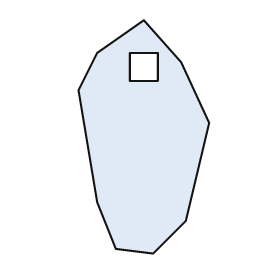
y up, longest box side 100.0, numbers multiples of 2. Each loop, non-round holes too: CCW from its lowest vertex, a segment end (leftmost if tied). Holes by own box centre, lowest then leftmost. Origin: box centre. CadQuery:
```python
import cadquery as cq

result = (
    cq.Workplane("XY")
    .moveTo(4.0, -50.0)
    .lineTo(18.0, -36.0)
    .lineTo(28.0, 6.0)
    .lineTo(16.0, 32.0)
    .lineTo(0.0, 50.0)
    .lineTo(-20.0, 36.0)
    .lineTo(-28.0, 20.0)
    .lineTo(-20.0, -28.0)
    .lineTo(-12.0, -48.0)
    .close()
    .moveTo(-6.0, 24.0)
    .lineTo(6.0, 24.0)
    .lineTo(6.0, 36.0)
    .lineTo(-6.0, 36.0)
    .close()
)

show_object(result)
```